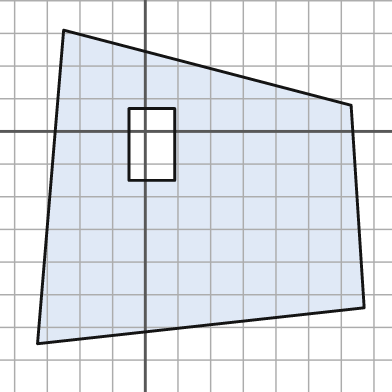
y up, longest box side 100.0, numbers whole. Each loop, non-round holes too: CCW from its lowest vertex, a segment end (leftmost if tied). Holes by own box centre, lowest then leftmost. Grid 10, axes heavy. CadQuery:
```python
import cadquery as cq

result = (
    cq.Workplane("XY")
    .moveTo(-33.0, -65.0)
    .lineTo(67.0, -54.0)
    .lineTo(63.0, 8.0)
    .lineTo(-25.0, 31.0)
    .close()
    .moveTo(-5.0, -15.0)
    .lineTo(9.0, -15.0)
    .lineTo(9.0, 7.0)
    .lineTo(-5.0, 7.0)
    .close()
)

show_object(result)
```